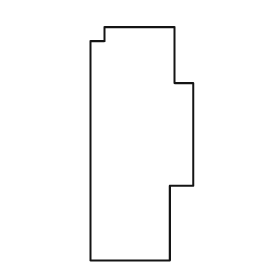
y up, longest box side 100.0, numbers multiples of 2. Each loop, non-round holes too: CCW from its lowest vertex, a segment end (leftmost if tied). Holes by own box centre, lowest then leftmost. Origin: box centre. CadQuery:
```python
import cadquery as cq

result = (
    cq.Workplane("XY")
    .moveTo(-22.0, -50.0)
    .lineTo(12.0, -50.0)
    .lineTo(12.0, -18.0)
    .lineTo(22.0, -18.0)
    .lineTo(22.0, 26.0)
    .lineTo(14.0, 26.0)
    .lineTo(14.0, 50.0)
    .lineTo(-16.0, 50.0)
    .lineTo(-16.0, 44.0)
    .lineTo(-22.0, 44.0)
    .close()
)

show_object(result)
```